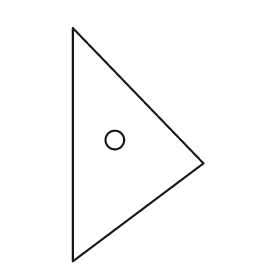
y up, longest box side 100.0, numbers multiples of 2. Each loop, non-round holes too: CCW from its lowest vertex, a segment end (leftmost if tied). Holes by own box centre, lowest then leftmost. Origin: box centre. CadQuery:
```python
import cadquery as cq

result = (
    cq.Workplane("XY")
    .moveTo(-28.0, -50.0)
    .lineTo(28.0, -8.0)
    .lineTo(-28.0, 50.0)
    .close()
    .moveTo(-10.0, 2.0)
    .circle(4.0)
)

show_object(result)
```